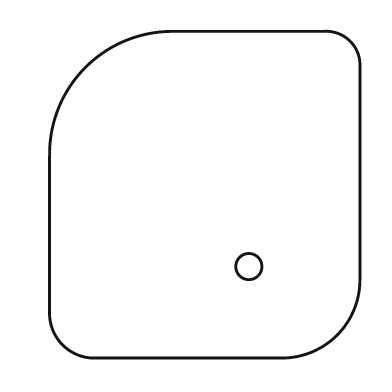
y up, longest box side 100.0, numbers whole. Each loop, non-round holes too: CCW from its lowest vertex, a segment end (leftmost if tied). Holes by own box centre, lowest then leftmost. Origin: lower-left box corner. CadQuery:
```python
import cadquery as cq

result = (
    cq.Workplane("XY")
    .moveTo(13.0, 0.0)
    .lineTo(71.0, 0.0)
    .threePointArc((88.0, 7.0), (95.0, 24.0))
    .lineTo(95.0, 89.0)
    .threePointArc((92.0, 97.0), (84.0, 100.0))
    .lineTo(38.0, 100.0)
    .threePointArc((11.0, 89.0), (0.0, 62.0))
    .lineTo(0.0, 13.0)
    .threePointArc((4.0, 4.0), (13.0, 0.0))
    .close()
    .moveTo(61.0, 28.0)
    .circle(4.0)
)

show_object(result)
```